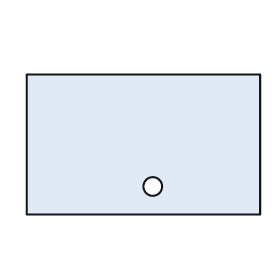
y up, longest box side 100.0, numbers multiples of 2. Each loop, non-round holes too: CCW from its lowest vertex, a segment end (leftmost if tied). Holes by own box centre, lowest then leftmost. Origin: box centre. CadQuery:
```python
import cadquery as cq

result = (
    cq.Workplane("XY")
    .moveTo(-50.0, -30.0)
    .lineTo(50.0, -30.0)
    .lineTo(50.0, 30.0)
    .lineTo(-50.0, 30.0)
    .close()
    .moveTo(4.0, -18.0)
    .circle(4.0)
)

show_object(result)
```